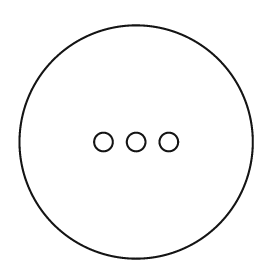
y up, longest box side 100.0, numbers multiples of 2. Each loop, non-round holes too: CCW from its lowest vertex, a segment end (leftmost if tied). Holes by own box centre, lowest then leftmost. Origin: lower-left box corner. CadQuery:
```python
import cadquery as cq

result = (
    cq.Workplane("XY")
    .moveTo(50.0, 50.0)
    .circle(50.0)
    .moveTo(36.0, 50.0)
    .circle(4.0)
    .moveTo(50.0, 50.0)
    .circle(4.0)
    .moveTo(64.0, 50.0)
    .circle(4.0)
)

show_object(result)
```